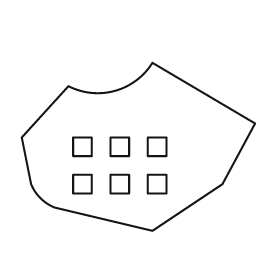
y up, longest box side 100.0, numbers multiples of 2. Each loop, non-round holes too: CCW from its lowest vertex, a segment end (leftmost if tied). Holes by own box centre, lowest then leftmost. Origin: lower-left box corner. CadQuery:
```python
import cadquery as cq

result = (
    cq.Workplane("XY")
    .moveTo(56.0, 0.0)
    .lineTo(86.0, 20.0)
    .lineTo(100.0, 46.0)
    .lineTo(56.0, 72.0)
    .threePointArc((40.0, 60.0), (20.0, 62.0))
    .lineTo(0.0, 40.0)
    .lineTo(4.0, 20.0)
    .threePointArc((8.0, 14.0), (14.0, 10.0))
    .close()
    .moveTo(22.0, 16.0)
    .lineTo(30.0, 16.0)
    .lineTo(30.0, 24.0)
    .lineTo(22.0, 24.0)
    .close()
    .moveTo(38.0, 16.0)
    .lineTo(46.0, 16.0)
    .lineTo(46.0, 24.0)
    .lineTo(38.0, 24.0)
    .close()
    .moveTo(54.0, 16.0)
    .lineTo(62.0, 16.0)
    .lineTo(62.0, 24.0)
    .lineTo(54.0, 24.0)
    .close()
    .moveTo(22.0, 32.0)
    .lineTo(30.0, 32.0)
    .lineTo(30.0, 40.0)
    .lineTo(22.0, 40.0)
    .close()
    .moveTo(38.0, 32.0)
    .lineTo(46.0, 32.0)
    .lineTo(46.0, 40.0)
    .lineTo(38.0, 40.0)
    .close()
    .moveTo(54.0, 32.0)
    .lineTo(62.0, 32.0)
    .lineTo(62.0, 40.0)
    .lineTo(54.0, 40.0)
    .close()
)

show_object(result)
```